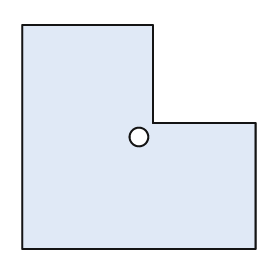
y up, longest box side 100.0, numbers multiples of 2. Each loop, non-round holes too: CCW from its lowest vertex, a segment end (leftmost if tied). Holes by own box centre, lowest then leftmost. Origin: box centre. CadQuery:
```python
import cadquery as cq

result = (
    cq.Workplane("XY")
    .moveTo(-50.0, -48.0)
    .lineTo(50.0, -48.0)
    .lineTo(50.0, 6.0)
    .lineTo(6.0, 6.0)
    .lineTo(6.0, 48.0)
    .lineTo(-50.0, 48.0)
    .close()
    .moveTo(0.0, 0.0)
    .circle(4.0)
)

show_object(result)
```